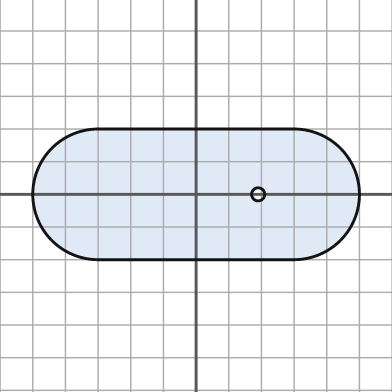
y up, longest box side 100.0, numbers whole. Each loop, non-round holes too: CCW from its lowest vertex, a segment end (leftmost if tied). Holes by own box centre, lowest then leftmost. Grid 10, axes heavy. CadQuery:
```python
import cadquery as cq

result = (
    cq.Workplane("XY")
    .moveTo(-30.0, -20.0)
    .lineTo(30.0, -20.0)
    .threePointArc((50.0, 0.0), (30.0, 20.0))
    .lineTo(-30.0, 20.0)
    .threePointArc((-50.0, 0.0), (-30.0, -20.0))
    .close()
    .moveTo(19.0, 0.0)
    .circle(2.0)
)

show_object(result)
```